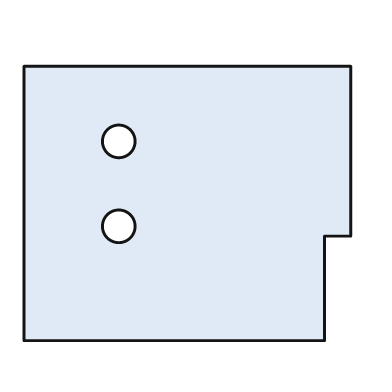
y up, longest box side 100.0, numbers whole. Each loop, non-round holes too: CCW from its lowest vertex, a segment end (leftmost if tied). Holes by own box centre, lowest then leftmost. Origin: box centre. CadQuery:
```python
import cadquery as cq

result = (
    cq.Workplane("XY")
    .moveTo(-50.0, -42.0)
    .lineTo(42.0, -42.0)
    .lineTo(42.0, -10.0)
    .lineTo(50.0, -10.0)
    .lineTo(50.0, 42.0)
    .lineTo(-50.0, 42.0)
    .close()
    .moveTo(-21.0, -7.0)
    .circle(5.0)
    .moveTo(-21.0, 19.0)
    .circle(5.0)
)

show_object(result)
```